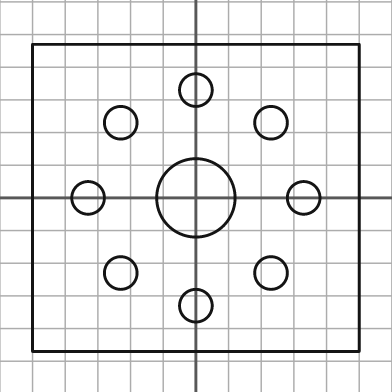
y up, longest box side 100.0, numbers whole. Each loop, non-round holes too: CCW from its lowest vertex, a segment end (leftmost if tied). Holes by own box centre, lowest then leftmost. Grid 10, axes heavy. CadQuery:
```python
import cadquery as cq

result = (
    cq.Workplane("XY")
    .moveTo(-50.0, -47.0)
    .lineTo(50.0, -47.0)
    .lineTo(50.0, 47.0)
    .lineTo(-50.0, 47.0)
    .close()
    .moveTo(0.0, -33.0)
    .circle(5.0)
    .moveTo(-23.0, -23.0)
    .circle(5.0)
    .moveTo(23.0, -23.0)
    .circle(5.0)
    .moveTo(-33.0, 0.0)
    .circle(5.0)
    .moveTo(0.0, 0.0)
    .circle(12.0)
    .moveTo(33.0, 0.0)
    .circle(5.0)
    .moveTo(-23.0, 23.0)
    .circle(5.0)
    .moveTo(23.0, 23.0)
    .circle(5.0)
    .moveTo(0.0, 33.0)
    .circle(5.0)
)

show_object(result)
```